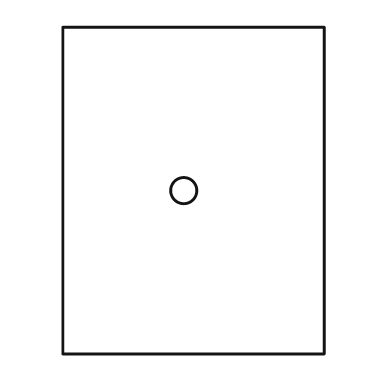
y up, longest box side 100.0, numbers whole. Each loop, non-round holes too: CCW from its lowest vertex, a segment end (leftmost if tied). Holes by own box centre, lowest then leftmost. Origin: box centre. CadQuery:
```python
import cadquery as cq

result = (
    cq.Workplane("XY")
    .moveTo(-40.0, -50.0)
    .lineTo(40.0, -50.0)
    .lineTo(40.0, 50.0)
    .lineTo(-40.0, 50.0)
    .close()
    .moveTo(-3.0, 0.0)
    .circle(4.0)
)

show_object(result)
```